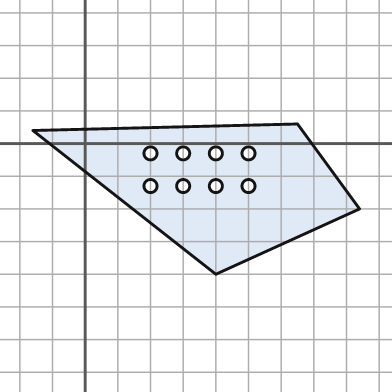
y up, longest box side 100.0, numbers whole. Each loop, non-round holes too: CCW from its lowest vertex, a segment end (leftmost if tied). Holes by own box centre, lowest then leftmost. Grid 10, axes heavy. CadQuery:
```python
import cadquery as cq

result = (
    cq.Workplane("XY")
    .moveTo(40.0, -40.0)
    .lineTo(84.0, -20.0)
    .lineTo(65.0, 6.0)
    .lineTo(-16.0, 4.0)
    .close()
    .moveTo(20.0, -13.0)
    .circle(2.0)
    .moveTo(30.0, -13.0)
    .circle(2.0)
    .moveTo(40.0, -13.0)
    .circle(2.0)
    .moveTo(50.0, -13.0)
    .circle(2.0)
    .moveTo(20.0, -3.0)
    .circle(2.0)
    .moveTo(30.0, -3.0)
    .circle(2.0)
    .moveTo(40.0, -3.0)
    .circle(2.0)
    .moveTo(50.0, -3.0)
    .circle(2.0)
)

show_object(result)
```